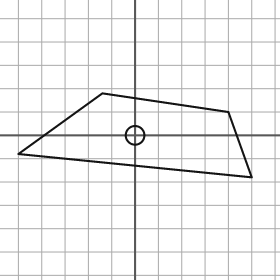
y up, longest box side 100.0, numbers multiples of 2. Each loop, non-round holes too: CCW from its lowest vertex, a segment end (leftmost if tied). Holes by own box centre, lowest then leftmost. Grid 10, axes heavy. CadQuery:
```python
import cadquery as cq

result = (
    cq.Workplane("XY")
    .moveTo(50.0, -18.0)
    .lineTo(40.0, 10.0)
    .lineTo(-14.0, 18.0)
    .lineTo(-50.0, -8.0)
    .close()
    .moveTo(0.0, 0.0)
    .circle(4.0)
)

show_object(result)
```